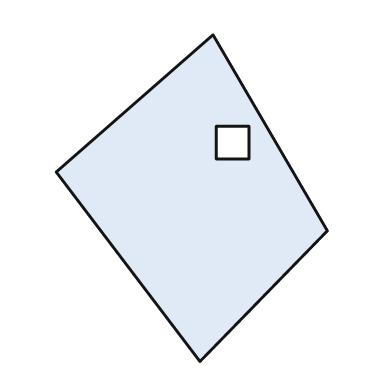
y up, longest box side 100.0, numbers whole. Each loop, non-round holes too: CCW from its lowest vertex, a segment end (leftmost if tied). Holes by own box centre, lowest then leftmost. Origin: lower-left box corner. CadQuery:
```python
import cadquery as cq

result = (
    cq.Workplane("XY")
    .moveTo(44.0, 0.0)
    .lineTo(83.0, 40.0)
    .lineTo(48.0, 100.0)
    .lineTo(0.0, 58.0)
    .close()
    .moveTo(49.0, 62.0)
    .lineTo(59.0, 62.0)
    .lineTo(59.0, 72.0)
    .lineTo(49.0, 72.0)
    .close()
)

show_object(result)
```